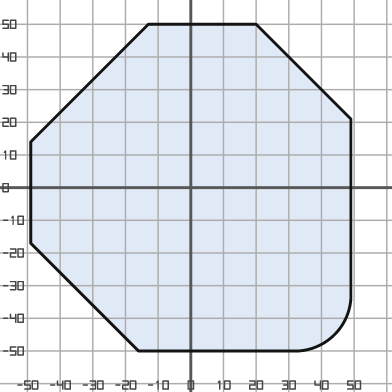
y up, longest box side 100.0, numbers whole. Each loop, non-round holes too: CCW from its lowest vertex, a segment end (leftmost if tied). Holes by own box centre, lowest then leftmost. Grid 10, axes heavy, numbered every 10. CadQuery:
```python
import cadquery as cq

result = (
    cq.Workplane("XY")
    .moveTo(-16.0, -50.0)
    .lineTo(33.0, -50.0)
    .threePointArc((44.0, -45.0), (49.0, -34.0))
    .lineTo(49.0, 21.0)
    .lineTo(20.0, 50.0)
    .lineTo(-13.0, 50.0)
    .lineTo(-49.0, 14.0)
    .lineTo(-49.0, -17.0)
    .close()
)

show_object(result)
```